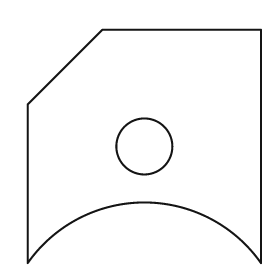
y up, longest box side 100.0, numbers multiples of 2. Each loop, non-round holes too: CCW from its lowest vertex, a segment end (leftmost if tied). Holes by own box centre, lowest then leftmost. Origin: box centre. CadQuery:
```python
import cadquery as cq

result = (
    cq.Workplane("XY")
    .moveTo(-50.0, -50.0)
    .threePointArc((0.0, -24.0), (50.0, -50.0))
    .lineTo(50.0, 50.0)
    .lineTo(-18.0, 50.0)
    .lineTo(-50.0, 18.0)
    .close()
    .moveTo(0.0, 0.0)
    .circle(12.0)
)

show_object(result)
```